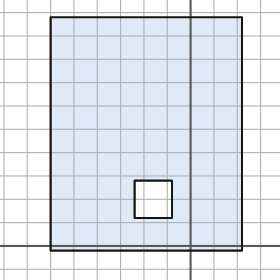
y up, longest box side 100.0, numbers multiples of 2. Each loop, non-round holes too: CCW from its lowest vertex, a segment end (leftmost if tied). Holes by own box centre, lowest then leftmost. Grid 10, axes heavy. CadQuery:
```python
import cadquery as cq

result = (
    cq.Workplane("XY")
    .moveTo(-60.0, -2.0)
    .lineTo(22.0, -2.0)
    .lineTo(22.0, 98.0)
    .lineTo(-60.0, 98.0)
    .close()
    .moveTo(-24.0, 12.0)
    .lineTo(-8.0, 12.0)
    .lineTo(-8.0, 28.0)
    .lineTo(-24.0, 28.0)
    .close()
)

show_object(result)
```